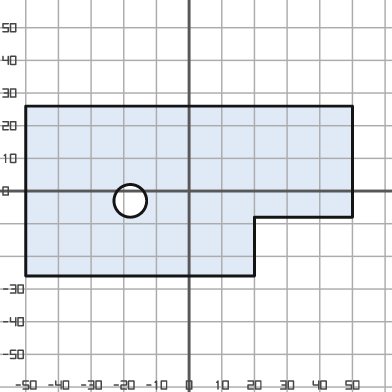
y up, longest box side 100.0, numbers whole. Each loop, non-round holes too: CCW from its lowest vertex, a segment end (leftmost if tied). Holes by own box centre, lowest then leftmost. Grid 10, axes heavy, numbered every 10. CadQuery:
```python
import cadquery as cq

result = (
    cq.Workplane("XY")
    .moveTo(-50.0, -26.0)
    .lineTo(20.0, -26.0)
    .lineTo(20.0, -8.0)
    .lineTo(50.0, -8.0)
    .lineTo(50.0, 26.0)
    .lineTo(-50.0, 26.0)
    .close()
    .moveTo(-18.0, -3.0)
    .circle(5.0)
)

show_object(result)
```